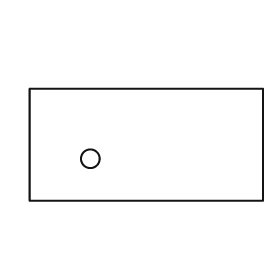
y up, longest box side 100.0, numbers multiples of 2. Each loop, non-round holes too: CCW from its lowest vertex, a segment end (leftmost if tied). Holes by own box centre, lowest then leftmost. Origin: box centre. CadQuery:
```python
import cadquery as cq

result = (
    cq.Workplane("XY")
    .moveTo(-50.0, -24.0)
    .lineTo(50.0, -24.0)
    .lineTo(50.0, 24.0)
    .lineTo(-50.0, 24.0)
    .close()
    .moveTo(-24.0, -6.0)
    .circle(4.0)
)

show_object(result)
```